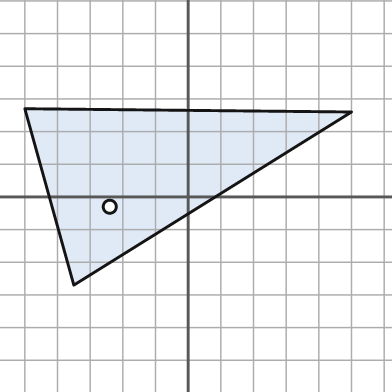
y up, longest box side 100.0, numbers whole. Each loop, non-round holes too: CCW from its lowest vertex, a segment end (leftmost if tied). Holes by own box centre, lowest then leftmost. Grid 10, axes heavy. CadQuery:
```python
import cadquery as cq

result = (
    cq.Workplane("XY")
    .moveTo(-35.0, -27.0)
    .lineTo(50.0, 26.0)
    .lineTo(-50.0, 27.0)
    .close()
    .moveTo(-24.0, -3.0)
    .circle(2.0)
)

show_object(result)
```